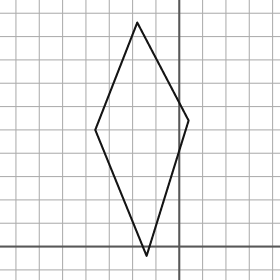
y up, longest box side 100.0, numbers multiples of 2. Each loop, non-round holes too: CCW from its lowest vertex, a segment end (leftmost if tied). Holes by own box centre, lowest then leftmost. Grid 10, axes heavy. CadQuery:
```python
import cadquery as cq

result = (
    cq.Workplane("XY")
    .moveTo(-14.0, -4.0)
    .lineTo(4.0, 54.0)
    .lineTo(-18.0, 96.0)
    .lineTo(-36.0, 50.0)
    .close()
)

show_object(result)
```